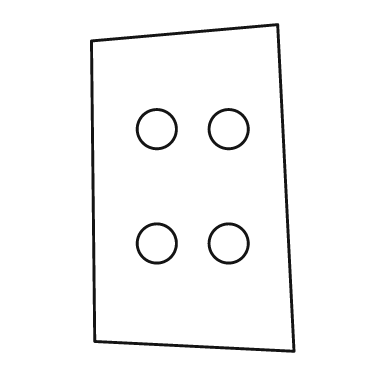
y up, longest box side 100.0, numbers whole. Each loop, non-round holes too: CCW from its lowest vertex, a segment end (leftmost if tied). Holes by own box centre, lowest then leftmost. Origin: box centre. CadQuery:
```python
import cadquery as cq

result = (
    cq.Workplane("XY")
    .moveTo(31.0, -50.0)
    .lineTo(26.0, 50.0)
    .lineTo(-31.0, 45.0)
    .lineTo(-30.0, -47.0)
    .close()
    .moveTo(-11.0, -17.0)
    .circle(6.0)
    .moveTo(11.0, -17.0)
    .circle(6.0)
    .moveTo(-11.0, 18.0)
    .circle(6.0)
    .moveTo(11.0, 18.0)
    .circle(6.0)
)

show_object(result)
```